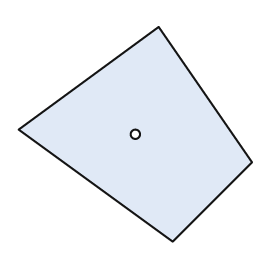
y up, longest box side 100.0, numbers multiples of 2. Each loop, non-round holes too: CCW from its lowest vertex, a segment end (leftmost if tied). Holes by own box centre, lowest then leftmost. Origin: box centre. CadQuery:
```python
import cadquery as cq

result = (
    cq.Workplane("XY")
    .moveTo(16.0, -46.0)
    .lineTo(50.0, -12.0)
    .lineTo(10.0, 46.0)
    .lineTo(-50.0, 2.0)
    .close()
    .moveTo(0.0, 0.0)
    .circle(2.0)
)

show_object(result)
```